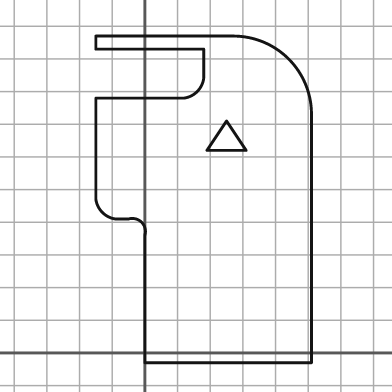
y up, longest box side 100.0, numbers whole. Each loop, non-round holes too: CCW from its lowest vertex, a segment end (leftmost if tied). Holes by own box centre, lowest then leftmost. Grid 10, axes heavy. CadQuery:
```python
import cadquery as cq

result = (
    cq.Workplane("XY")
    .moveTo(0.0, -3.0)
    .lineTo(51.0, -3.0)
    .lineTo(51.0, 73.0)
    .threePointArc((44.0, 90.0), (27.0, 97.0))
    .lineTo(-15.0, 97.0)
    .lineTo(-15.0, 93.0)
    .lineTo(18.0, 93.0)
    .lineTo(18.0, 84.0)
    .threePointArc((16.0, 80.0), (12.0, 78.0))
    .lineTo(-15.0, 78.0)
    .lineTo(-15.0, 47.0)
    .threePointArc((-13.0, 43.0), (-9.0, 41.0))
    .lineTo(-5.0, 41.0)
    .threePointArc((-1.0, 40.0), (0.0, 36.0))
    .close()
    .moveTo(19.0, 62.0)
    .lineTo(31.0, 62.0)
    .lineTo(25.0, 71.0)
    .close()
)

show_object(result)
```